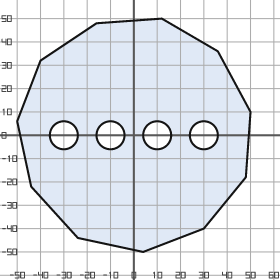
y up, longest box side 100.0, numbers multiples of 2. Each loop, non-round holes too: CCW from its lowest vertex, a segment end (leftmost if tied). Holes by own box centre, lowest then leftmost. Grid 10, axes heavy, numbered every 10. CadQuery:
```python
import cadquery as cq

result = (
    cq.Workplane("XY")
    .moveTo(4.0, -50.0)
    .lineTo(30.0, -40.0)
    .lineTo(48.0, -18.0)
    .lineTo(50.0, 10.0)
    .lineTo(36.0, 36.0)
    .lineTo(12.0, 50.0)
    .lineTo(-16.0, 48.0)
    .lineTo(-40.0, 32.0)
    .lineTo(-50.0, 6.0)
    .lineTo(-44.0, -22.0)
    .lineTo(-24.0, -44.0)
    .close()
    .moveTo(-30.0, 0.0)
    .circle(6.0)
    .moveTo(-10.0, 0.0)
    .circle(6.0)
    .moveTo(10.0, 0.0)
    .circle(6.0)
    .moveTo(30.0, 0.0)
    .circle(6.0)
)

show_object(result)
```